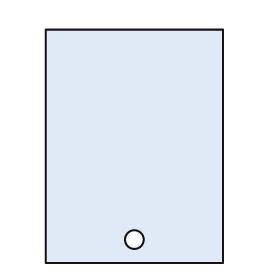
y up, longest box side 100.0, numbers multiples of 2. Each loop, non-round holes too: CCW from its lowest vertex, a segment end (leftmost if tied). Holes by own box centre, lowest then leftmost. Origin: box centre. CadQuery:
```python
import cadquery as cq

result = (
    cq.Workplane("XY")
    .moveTo(-38.0, -50.0)
    .lineTo(38.0, -50.0)
    .lineTo(38.0, 50.0)
    .lineTo(-38.0, 50.0)
    .close()
    .moveTo(0.0, -40.0)
    .circle(4.0)
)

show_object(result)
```